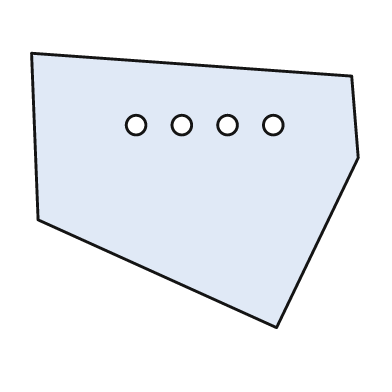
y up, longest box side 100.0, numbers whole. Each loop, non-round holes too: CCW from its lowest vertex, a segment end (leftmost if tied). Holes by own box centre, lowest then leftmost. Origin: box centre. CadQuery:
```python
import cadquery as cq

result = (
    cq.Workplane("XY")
    .moveTo(25.0, -42.0)
    .lineTo(50.0, 10.0)
    .lineTo(48.0, 35.0)
    .lineTo(-50.0, 42.0)
    .lineTo(-48.0, -9.0)
    .close()
    .moveTo(-18.0, 20.0)
    .circle(3.0)
    .moveTo(-4.0, 20.0)
    .circle(3.0)
    .moveTo(10.0, 20.0)
    .circle(3.0)
    .moveTo(24.0, 20.0)
    .circle(3.0)
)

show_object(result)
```